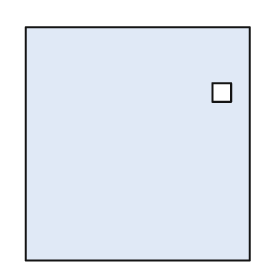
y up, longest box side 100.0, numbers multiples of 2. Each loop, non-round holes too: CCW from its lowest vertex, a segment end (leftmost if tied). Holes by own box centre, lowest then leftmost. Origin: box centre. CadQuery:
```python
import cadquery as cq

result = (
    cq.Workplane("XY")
    .moveTo(-48.0, -50.0)
    .lineTo(48.0, -50.0)
    .lineTo(48.0, 50.0)
    .lineTo(-48.0, 50.0)
    .close()
    .moveTo(32.0, 18.0)
    .lineTo(40.0, 18.0)
    .lineTo(40.0, 26.0)
    .lineTo(32.0, 26.0)
    .close()
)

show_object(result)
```